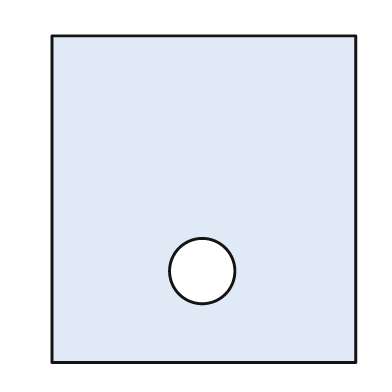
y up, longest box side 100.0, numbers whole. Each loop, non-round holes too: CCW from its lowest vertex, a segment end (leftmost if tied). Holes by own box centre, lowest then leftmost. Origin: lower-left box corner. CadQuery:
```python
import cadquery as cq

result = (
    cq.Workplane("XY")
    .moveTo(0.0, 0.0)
    .lineTo(93.0, 0.0)
    .lineTo(93.0, 100.0)
    .lineTo(0.0, 100.0)
    .close()
    .moveTo(46.0, 28.0)
    .circle(10.0)
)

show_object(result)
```